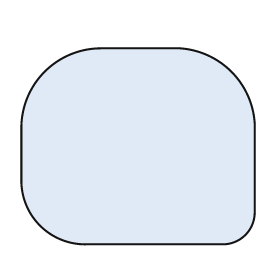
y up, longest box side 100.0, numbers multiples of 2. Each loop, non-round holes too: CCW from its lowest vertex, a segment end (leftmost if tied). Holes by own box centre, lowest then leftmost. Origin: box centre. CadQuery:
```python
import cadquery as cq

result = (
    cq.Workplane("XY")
    .moveTo(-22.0, -42.0)
    .lineTo(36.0, -42.0)
    .threePointArc((46.0, -38.0), (50.0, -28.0))
    .lineTo(50.0, 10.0)
    .threePointArc((40.0, 32.0), (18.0, 42.0))
    .lineTo(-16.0, 42.0)
    .threePointArc((-40.0, 32.0), (-50.0, 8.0))
    .lineTo(-50.0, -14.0)
    .threePointArc((-42.0, -34.0), (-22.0, -42.0))
    .close()
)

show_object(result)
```